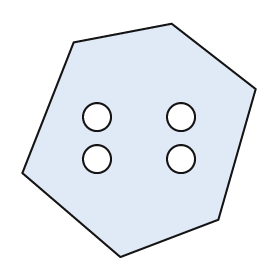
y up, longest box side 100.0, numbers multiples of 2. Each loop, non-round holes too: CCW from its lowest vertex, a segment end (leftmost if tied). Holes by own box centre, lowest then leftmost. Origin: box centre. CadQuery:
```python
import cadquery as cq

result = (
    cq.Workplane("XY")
    .moveTo(-8.0, -50.0)
    .lineTo(34.0, -34.0)
    .lineTo(50.0, 22.0)
    .lineTo(14.0, 50.0)
    .lineTo(-28.0, 42.0)
    .lineTo(-50.0, -14.0)
    .close()
    .moveTo(-18.0, -8.0)
    .circle(6.0)
    .moveTo(18.0, -8.0)
    .circle(6.0)
    .moveTo(-18.0, 10.0)
    .circle(6.0)
    .moveTo(18.0, 10.0)
    .circle(6.0)
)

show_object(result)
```